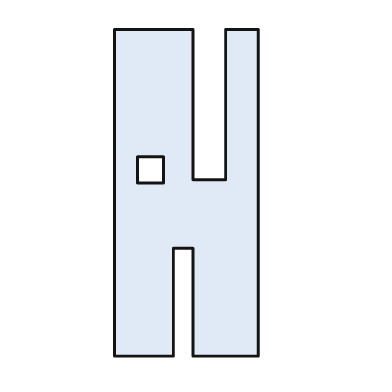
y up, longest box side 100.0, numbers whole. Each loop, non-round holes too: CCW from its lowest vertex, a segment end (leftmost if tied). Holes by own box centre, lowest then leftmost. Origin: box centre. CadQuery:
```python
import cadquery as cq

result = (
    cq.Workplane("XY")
    .moveTo(-22.0, -50.0)
    .lineTo(-4.0, -50.0)
    .lineTo(-4.0, -17.0)
    .lineTo(2.0, -17.0)
    .lineTo(2.0, -50.0)
    .lineTo(22.0, -50.0)
    .lineTo(22.0, 50.0)
    .lineTo(12.0, 50.0)
    .lineTo(12.0, 4.0)
    .lineTo(2.0, 4.0)
    .lineTo(2.0, 50.0)
    .lineTo(-22.0, 50.0)
    .close()
    .moveTo(-15.0, 3.0)
    .lineTo(-7.0, 3.0)
    .lineTo(-7.0, 11.0)
    .lineTo(-15.0, 11.0)
    .close()
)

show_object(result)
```